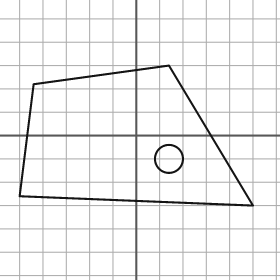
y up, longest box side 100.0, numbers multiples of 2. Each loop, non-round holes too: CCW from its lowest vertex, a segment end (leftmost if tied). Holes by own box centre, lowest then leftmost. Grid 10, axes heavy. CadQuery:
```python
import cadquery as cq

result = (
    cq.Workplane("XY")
    .moveTo(50.0, -30.0)
    .lineTo(14.0, 30.0)
    .lineTo(-44.0, 22.0)
    .lineTo(-50.0, -26.0)
    .close()
    .moveTo(14.0, -10.0)
    .circle(6.0)
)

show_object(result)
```